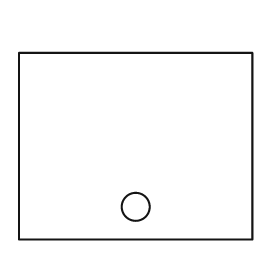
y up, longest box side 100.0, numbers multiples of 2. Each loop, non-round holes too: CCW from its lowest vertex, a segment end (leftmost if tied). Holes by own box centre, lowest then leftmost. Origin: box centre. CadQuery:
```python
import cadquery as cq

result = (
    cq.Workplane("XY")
    .moveTo(-50.0, -40.0)
    .lineTo(50.0, -40.0)
    .lineTo(50.0, 40.0)
    .lineTo(-50.0, 40.0)
    .close()
    .moveTo(0.0, -26.0)
    .circle(6.0)
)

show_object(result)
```